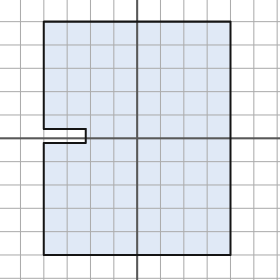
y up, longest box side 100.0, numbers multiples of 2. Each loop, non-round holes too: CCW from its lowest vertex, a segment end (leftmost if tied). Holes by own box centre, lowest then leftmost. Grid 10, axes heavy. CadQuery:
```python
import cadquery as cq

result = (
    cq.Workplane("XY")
    .moveTo(-40.0, -50.0)
    .lineTo(40.0, -50.0)
    .lineTo(40.0, 50.0)
    .lineTo(-40.0, 50.0)
    .lineTo(-40.0, 4.0)
    .lineTo(-22.0, 4.0)
    .lineTo(-22.0, -2.0)
    .lineTo(-40.0, -2.0)
    .close()
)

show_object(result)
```